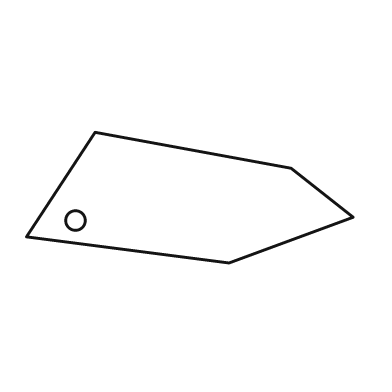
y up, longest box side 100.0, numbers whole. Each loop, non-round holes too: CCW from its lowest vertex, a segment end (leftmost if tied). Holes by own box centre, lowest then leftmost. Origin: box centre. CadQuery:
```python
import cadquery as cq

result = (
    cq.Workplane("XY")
    .moveTo(12.0, -20.0)
    .lineTo(50.0, -6.0)
    .lineTo(31.0, 9.0)
    .lineTo(-29.0, 20.0)
    .lineTo(-50.0, -12.0)
    .close()
    .moveTo(-35.0, -7.0)
    .circle(3.0)
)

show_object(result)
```